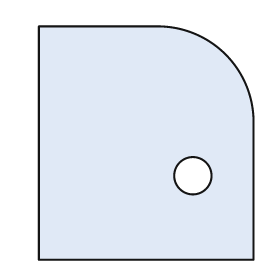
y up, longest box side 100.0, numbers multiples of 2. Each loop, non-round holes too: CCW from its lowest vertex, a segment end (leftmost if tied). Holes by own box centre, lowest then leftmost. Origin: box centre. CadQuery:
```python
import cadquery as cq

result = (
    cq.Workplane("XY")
    .moveTo(-46.0, -50.0)
    .lineTo(46.0, -50.0)
    .lineTo(46.0, 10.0)
    .threePointArc((34.0, 38.0), (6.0, 50.0))
    .lineTo(-46.0, 50.0)
    .close()
    .moveTo(20.0, -14.0)
    .circle(8.0)
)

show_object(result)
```